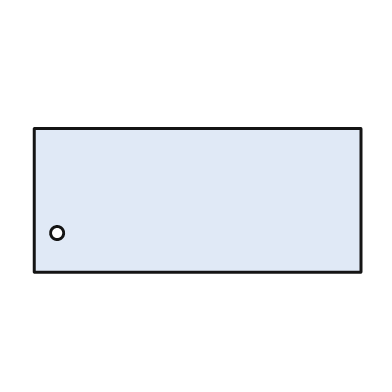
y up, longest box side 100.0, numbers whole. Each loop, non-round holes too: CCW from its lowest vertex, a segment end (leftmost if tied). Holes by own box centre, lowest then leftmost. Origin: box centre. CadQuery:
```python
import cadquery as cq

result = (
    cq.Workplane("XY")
    .moveTo(-50.0, -22.0)
    .lineTo(50.0, -22.0)
    .lineTo(50.0, 22.0)
    .lineTo(-50.0, 22.0)
    .close()
    .moveTo(-43.0, -10.0)
    .circle(2.0)
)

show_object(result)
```